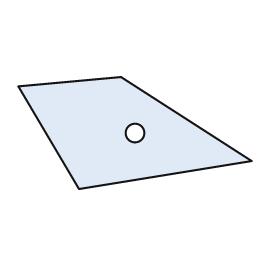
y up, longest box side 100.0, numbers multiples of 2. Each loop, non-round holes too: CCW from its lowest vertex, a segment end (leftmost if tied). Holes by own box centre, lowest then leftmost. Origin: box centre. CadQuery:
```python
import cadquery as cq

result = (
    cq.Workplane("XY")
    .moveTo(-24.0, -24.0)
    .lineTo(50.0, -12.0)
    .lineTo(-6.0, 24.0)
    .lineTo(-50.0, 20.0)
    .close()
    .moveTo(0.0, 0.0)
    .circle(4.0)
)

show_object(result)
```